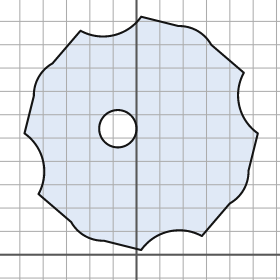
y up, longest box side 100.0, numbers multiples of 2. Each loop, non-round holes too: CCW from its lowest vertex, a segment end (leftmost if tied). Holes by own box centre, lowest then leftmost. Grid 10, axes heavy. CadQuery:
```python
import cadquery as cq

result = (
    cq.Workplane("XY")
    .moveTo(2.0, 2.0)
    .threePointArc((14.0, 10.0), (28.0, 8.0))
    .lineTo(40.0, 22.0)
    .threePointArc((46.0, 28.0), (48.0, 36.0))
    .lineTo(52.0, 52.0)
    .threePointArc((44.0, 64.0), (46.0, 78.0))
    .lineTo(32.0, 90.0)
    .threePointArc((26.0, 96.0), (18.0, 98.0))
    .lineTo(2.0, 102.0)
    .threePointArc((-10.0, 94.0), (-24.0, 96.0))
    .lineTo(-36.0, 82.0)
    .threePointArc((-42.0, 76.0), (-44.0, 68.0))
    .lineTo(-48.0, 52.0)
    .threePointArc((-40.0, 40.0), (-42.0, 26.0))
    .lineTo(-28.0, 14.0)
    .threePointArc((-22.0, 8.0), (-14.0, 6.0))
    .close()
    .moveTo(-8.0, 54.0)
    .circle(8.0)
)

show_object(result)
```